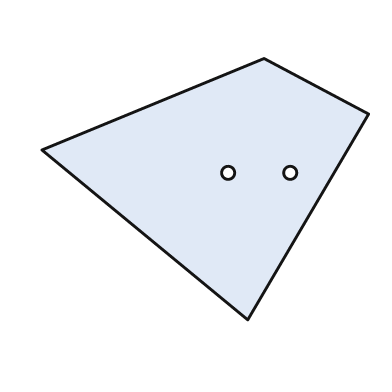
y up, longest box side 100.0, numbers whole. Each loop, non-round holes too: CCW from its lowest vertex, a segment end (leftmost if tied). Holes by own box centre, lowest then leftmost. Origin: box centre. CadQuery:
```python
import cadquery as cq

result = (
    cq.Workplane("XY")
    .moveTo(13.0, -40.0)
    .lineTo(50.0, 23.0)
    .lineTo(18.0, 40.0)
    .lineTo(-50.0, 12.0)
    .close()
    .moveTo(7.0, 5.0)
    .circle(2.0)
    .moveTo(26.0, 5.0)
    .circle(2.0)
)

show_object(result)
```